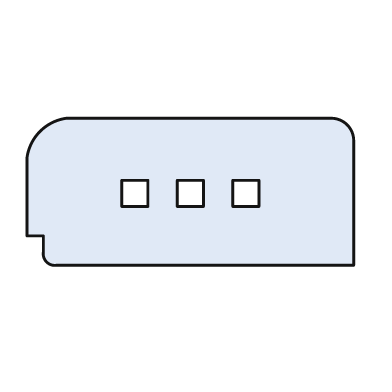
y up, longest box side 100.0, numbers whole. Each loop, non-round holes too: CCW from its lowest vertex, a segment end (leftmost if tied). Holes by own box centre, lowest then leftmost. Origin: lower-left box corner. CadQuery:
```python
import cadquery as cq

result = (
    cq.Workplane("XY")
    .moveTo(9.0, 0.0)
    .lineTo(100.0, 0.0)
    .lineTo(100.0, 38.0)
    .threePointArc((98.0, 43.0), (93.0, 45.0))
    .lineTo(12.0, 45.0)
    .threePointArc((4.0, 41.0), (0.0, 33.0))
    .lineTo(0.0, 9.0)
    .lineTo(5.0, 9.0)
    .lineTo(5.0, 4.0)
    .threePointArc((6.0, 1.0), (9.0, 0.0))
    .close()
    .moveTo(29.0, 18.0)
    .lineTo(37.0, 18.0)
    .lineTo(37.0, 26.0)
    .lineTo(29.0, 26.0)
    .close()
    .moveTo(46.0, 18.0)
    .lineTo(54.0, 18.0)
    .lineTo(54.0, 26.0)
    .lineTo(46.0, 26.0)
    .close()
    .moveTo(63.0, 18.0)
    .lineTo(71.0, 18.0)
    .lineTo(71.0, 26.0)
    .lineTo(63.0, 26.0)
    .close()
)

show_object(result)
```